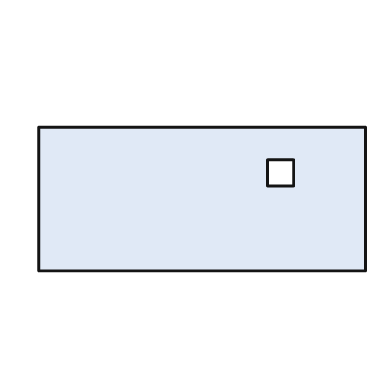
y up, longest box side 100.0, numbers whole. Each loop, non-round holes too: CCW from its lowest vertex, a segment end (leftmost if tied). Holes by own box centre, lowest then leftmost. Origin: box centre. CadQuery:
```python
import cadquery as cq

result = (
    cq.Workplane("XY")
    .moveTo(-50.0, -22.0)
    .lineTo(50.0, -22.0)
    .lineTo(50.0, 22.0)
    .lineTo(-50.0, 22.0)
    .close()
    .moveTo(20.0, 4.0)
    .lineTo(28.0, 4.0)
    .lineTo(28.0, 12.0)
    .lineTo(20.0, 12.0)
    .close()
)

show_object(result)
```